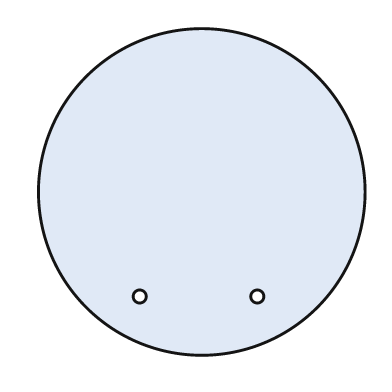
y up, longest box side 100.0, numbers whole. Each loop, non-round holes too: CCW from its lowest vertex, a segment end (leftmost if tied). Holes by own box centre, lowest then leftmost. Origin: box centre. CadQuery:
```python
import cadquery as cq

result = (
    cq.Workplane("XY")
    .moveTo(0.0, 0.0)
    .circle(50.0)
    .moveTo(-19.0, -32.0)
    .circle(2.0)
    .moveTo(17.0, -32.0)
    .circle(2.0)
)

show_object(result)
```